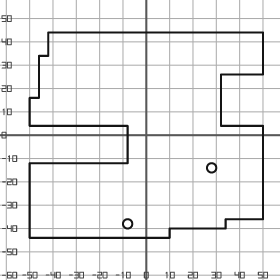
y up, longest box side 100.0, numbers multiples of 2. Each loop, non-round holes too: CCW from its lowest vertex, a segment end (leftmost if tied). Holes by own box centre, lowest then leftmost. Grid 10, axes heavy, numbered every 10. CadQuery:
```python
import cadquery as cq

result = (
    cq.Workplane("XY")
    .moveTo(-50.0, -44.0)
    .lineTo(10.0, -44.0)
    .lineTo(10.0, -40.0)
    .lineTo(34.0, -40.0)
    .lineTo(34.0, -36.0)
    .lineTo(50.0, -36.0)
    .lineTo(50.0, 4.0)
    .lineTo(32.0, 4.0)
    .lineTo(32.0, 26.0)
    .lineTo(50.0, 26.0)
    .lineTo(50.0, 44.0)
    .lineTo(-42.0, 44.0)
    .lineTo(-42.0, 34.0)
    .lineTo(-46.0, 34.0)
    .lineTo(-46.0, 16.0)
    .lineTo(-50.0, 16.0)
    .lineTo(-50.0, 4.0)
    .lineTo(-8.0, 4.0)
    .lineTo(-8.0, -12.0)
    .lineTo(-50.0, -12.0)
    .close()
    .moveTo(-8.0, -38.0)
    .circle(2.0)
    .moveTo(28.0, -14.0)
    .circle(2.0)
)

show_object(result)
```